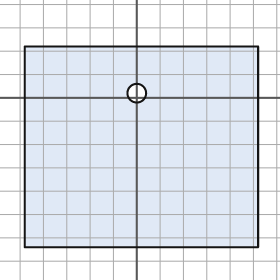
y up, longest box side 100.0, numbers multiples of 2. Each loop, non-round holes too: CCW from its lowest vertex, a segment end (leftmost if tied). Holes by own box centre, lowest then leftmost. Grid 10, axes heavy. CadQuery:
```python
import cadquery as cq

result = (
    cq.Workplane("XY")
    .moveTo(-48.0, -64.0)
    .lineTo(52.0, -64.0)
    .lineTo(52.0, 22.0)
    .lineTo(-48.0, 22.0)
    .close()
    .moveTo(0.0, 2.0)
    .circle(4.0)
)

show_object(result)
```